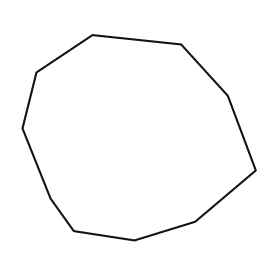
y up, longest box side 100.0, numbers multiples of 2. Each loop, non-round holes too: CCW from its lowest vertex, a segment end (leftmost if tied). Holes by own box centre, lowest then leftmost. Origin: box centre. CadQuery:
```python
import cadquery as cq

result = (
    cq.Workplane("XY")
    .moveTo(-2.0, -44.0)
    .lineTo(24.0, -36.0)
    .lineTo(50.0, -14.0)
    .lineTo(38.0, 18.0)
    .lineTo(18.0, 40.0)
    .lineTo(-20.0, 44.0)
    .lineTo(-44.0, 28.0)
    .lineTo(-50.0, 4.0)
    .lineTo(-38.0, -26.0)
    .lineTo(-28.0, -40.0)
    .close()
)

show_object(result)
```